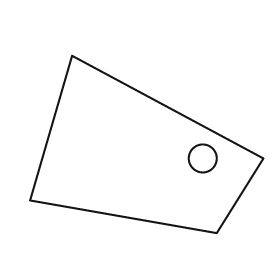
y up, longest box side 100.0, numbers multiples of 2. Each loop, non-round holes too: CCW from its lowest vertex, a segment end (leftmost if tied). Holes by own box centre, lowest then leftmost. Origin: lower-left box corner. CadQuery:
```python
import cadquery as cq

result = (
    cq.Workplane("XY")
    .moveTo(80.0, 0.0)
    .lineTo(100.0, 32.0)
    .lineTo(18.0, 76.0)
    .lineTo(0.0, 14.0)
    .close()
    .moveTo(74.0, 32.0)
    .circle(6.0)
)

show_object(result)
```